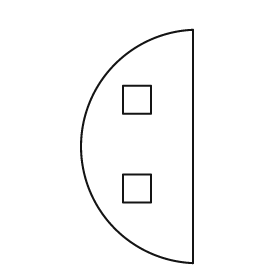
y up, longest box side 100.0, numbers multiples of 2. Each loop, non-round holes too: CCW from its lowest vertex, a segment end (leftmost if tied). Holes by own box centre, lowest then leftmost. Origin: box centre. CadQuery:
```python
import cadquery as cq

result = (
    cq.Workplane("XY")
    .moveTo(24.0, -50.0)
    .lineTo(24.0, 50.0)
    .threePointArc((-24.0, 0.0), (24.0, -50.0))
    .close()
    .moveTo(-6.0, -24.0)
    .lineTo(6.0, -24.0)
    .lineTo(6.0, -12.0)
    .lineTo(-6.0, -12.0)
    .close()
    .moveTo(-6.0, 14.0)
    .lineTo(6.0, 14.0)
    .lineTo(6.0, 26.0)
    .lineTo(-6.0, 26.0)
    .close()
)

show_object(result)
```